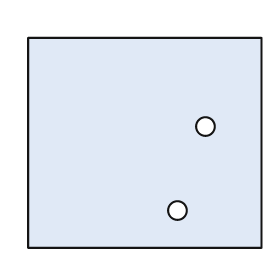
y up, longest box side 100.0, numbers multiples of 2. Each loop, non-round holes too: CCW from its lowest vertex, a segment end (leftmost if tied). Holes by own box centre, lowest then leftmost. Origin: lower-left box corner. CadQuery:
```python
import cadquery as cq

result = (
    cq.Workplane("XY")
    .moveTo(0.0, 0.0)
    .lineTo(100.0, 0.0)
    .lineTo(100.0, 90.0)
    .lineTo(0.0, 90.0)
    .close()
    .moveTo(64.0, 16.0)
    .circle(4.0)
    .moveTo(76.0, 52.0)
    .circle(4.0)
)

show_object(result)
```